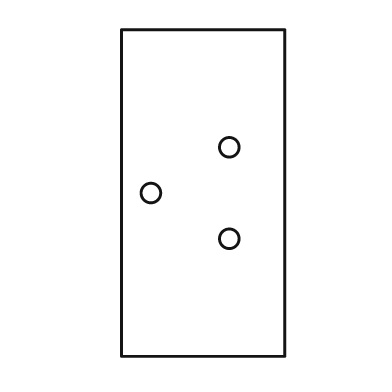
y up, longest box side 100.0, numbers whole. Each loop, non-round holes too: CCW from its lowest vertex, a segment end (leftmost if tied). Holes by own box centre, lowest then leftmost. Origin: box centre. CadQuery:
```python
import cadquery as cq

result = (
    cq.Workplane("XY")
    .moveTo(-25.0, -50.0)
    .lineTo(25.0, -50.0)
    .lineTo(25.0, 50.0)
    .lineTo(-25.0, 50.0)
    .close()
    .moveTo(8.0, -14.0)
    .circle(3.0)
    .moveTo(-16.0, 0.0)
    .circle(3.0)
    .moveTo(8.0, 14.0)
    .circle(3.0)
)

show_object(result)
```